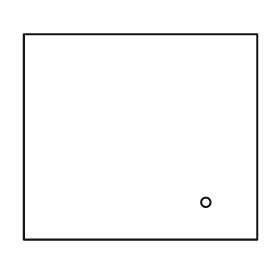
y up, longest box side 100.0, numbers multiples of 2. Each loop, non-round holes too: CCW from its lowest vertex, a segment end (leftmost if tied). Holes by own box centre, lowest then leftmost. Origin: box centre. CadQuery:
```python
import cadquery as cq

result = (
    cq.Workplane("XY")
    .moveTo(-50.0, -44.0)
    .lineTo(50.0, -44.0)
    .lineTo(50.0, 44.0)
    .lineTo(-50.0, 44.0)
    .close()
    .moveTo(28.0, -28.0)
    .circle(2.0)
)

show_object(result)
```